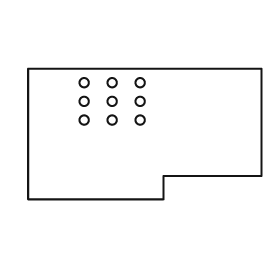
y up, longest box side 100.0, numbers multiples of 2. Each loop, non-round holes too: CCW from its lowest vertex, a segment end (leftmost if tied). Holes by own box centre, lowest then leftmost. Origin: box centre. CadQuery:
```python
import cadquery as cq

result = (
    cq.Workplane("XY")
    .moveTo(-50.0, -28.0)
    .lineTo(8.0, -28.0)
    .lineTo(8.0, -18.0)
    .lineTo(50.0, -18.0)
    .lineTo(50.0, 28.0)
    .lineTo(-50.0, 28.0)
    .close()
    .moveTo(-26.0, 6.0)
    .circle(2.0)
    .moveTo(-14.0, 6.0)
    .circle(2.0)
    .moveTo(-2.0, 6.0)
    .circle(2.0)
    .moveTo(-26.0, 14.0)
    .circle(2.0)
    .moveTo(-14.0, 14.0)
    .circle(2.0)
    .moveTo(-2.0, 14.0)
    .circle(2.0)
    .moveTo(-26.0, 22.0)
    .circle(2.0)
    .moveTo(-14.0, 22.0)
    .circle(2.0)
    .moveTo(-2.0, 22.0)
    .circle(2.0)
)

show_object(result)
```